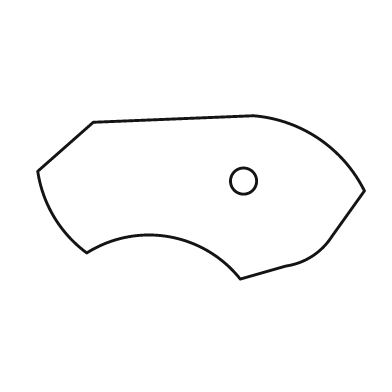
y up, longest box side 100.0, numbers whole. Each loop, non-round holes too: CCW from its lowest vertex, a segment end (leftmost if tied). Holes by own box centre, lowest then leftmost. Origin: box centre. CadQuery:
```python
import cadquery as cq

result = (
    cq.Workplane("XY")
    .moveTo(12.0, -25.0)
    .lineTo(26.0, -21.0)
    .threePointArc((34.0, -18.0), (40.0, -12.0))
    .lineTo(50.0, 2.0)
    .threePointArc((36.0, 18.0), (16.0, 25.0))
    .lineTo(-33.0, 23.0)
    .lineTo(-50.0, 8.0)
    .threePointArc((-45.0, -6.0), (-35.0, -17.0))
    .threePointArc((-10.0, -12.0), (12.0, -25.0))
    .close()
    .moveTo(13.0, 5.0)
    .circle(4.0)
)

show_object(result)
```